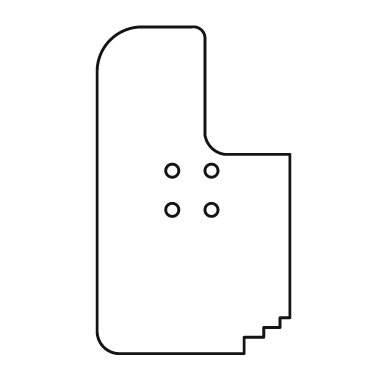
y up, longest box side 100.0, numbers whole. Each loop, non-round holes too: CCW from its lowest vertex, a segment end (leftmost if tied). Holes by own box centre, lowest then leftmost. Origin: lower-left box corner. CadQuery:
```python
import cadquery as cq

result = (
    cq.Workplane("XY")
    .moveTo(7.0, 0.0)
    .lineTo(45.0, 0.0)
    .lineTo(45.0, 5.0)
    .lineTo(51.0, 5.0)
    .lineTo(51.0, 8.0)
    .lineTo(56.0, 8.0)
    .lineTo(56.0, 11.0)
    .lineTo(59.0, 11.0)
    .lineTo(59.0, 61.0)
    .lineTo(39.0, 61.0)
    .threePointArc((35.0, 63.0), (33.0, 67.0))
    .lineTo(33.0, 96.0)
    .threePointArc((32.0, 99.0), (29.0, 100.0))
    .lineTo(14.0, 100.0)
    .threePointArc((4.0, 96.0), (0.0, 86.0))
    .lineTo(0.0, 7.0)
    .threePointArc((2.0, 2.0), (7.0, 0.0))
    .close()
    .moveTo(23.0, 44.0)
    .circle(2.0)
    .moveTo(35.0, 44.0)
    .circle(2.0)
    .moveTo(23.0, 56.0)
    .circle(2.0)
    .moveTo(35.0, 56.0)
    .circle(2.0)
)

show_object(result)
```